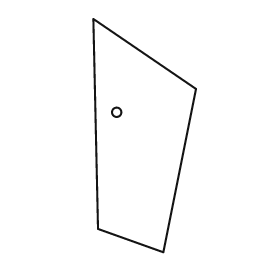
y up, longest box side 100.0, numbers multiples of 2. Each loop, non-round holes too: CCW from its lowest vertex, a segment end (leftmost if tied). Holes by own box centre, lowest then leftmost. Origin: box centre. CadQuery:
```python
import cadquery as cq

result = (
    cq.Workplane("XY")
    .moveTo(8.0, -50.0)
    .lineTo(22.0, 20.0)
    .lineTo(-22.0, 50.0)
    .lineTo(-20.0, -40.0)
    .close()
    .moveTo(-12.0, 10.0)
    .circle(2.0)
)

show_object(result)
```